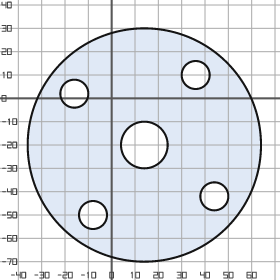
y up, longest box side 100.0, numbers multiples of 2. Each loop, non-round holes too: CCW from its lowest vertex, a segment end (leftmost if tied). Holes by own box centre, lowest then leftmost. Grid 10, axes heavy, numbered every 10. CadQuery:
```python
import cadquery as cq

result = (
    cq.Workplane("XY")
    .moveTo(14.0, -20.0)
    .circle(50.0)
    .moveTo(-8.0, -50.0)
    .circle(6.0)
    .moveTo(44.0, -42.0)
    .circle(6.0)
    .moveTo(14.0, -20.0)
    .circle(10.0)
    .moveTo(-16.0, 2.0)
    .circle(6.0)
    .moveTo(36.0, 10.0)
    .circle(6.0)
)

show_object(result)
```